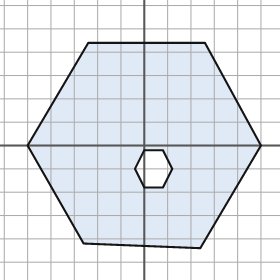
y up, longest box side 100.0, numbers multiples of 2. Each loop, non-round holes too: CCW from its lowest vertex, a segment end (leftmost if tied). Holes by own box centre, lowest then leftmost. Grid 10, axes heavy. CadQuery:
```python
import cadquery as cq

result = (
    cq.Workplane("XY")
    .moveTo(24.0, -44.0)
    .lineTo(50.0, 0.0)
    .lineTo(26.0, 44.0)
    .lineTo(-24.0, 44.0)
    .lineTo(-50.0, 0.0)
    .lineTo(-26.0, -42.0)
    .close()
    .moveTo(0.0, -18.0)
    .lineTo(8.0, -18.0)
    .lineTo(12.0, -10.0)
    .lineTo(8.0, -2.0)
    .lineTo(0.0, -2.0)
    .lineTo(-4.0, -10.0)
    .close()
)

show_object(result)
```